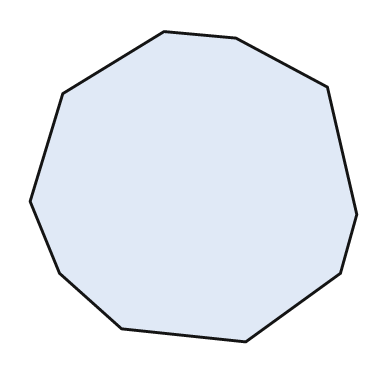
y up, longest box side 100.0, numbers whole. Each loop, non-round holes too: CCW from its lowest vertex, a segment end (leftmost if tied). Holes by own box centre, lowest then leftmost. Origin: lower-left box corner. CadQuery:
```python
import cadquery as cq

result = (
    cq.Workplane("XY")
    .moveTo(66.0, 0.0)
    .lineTo(95.0, 21.0)
    .lineTo(100.0, 39.0)
    .lineTo(91.0, 78.0)
    .lineTo(63.0, 93.0)
    .lineTo(41.0, 95.0)
    .lineTo(10.0, 76.0)
    .lineTo(0.0, 43.0)
    .lineTo(9.0, 21.0)
    .lineTo(28.0, 4.0)
    .close()
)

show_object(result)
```